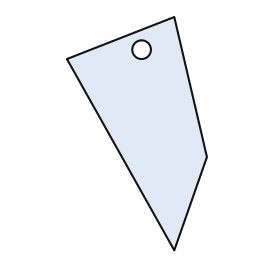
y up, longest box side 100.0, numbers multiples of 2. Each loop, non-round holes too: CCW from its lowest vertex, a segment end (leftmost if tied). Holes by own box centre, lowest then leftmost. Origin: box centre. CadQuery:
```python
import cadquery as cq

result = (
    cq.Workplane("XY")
    .moveTo(16.0, -50.0)
    .lineTo(30.0, -10.0)
    .lineTo(16.0, 50.0)
    .lineTo(-30.0, 32.0)
    .close()
    .moveTo(2.0, 36.0)
    .circle(4.0)
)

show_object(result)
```